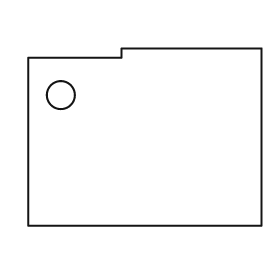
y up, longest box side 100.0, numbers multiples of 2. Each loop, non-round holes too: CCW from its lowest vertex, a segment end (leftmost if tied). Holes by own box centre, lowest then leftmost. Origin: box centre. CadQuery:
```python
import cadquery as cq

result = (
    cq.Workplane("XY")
    .moveTo(-50.0, -38.0)
    .lineTo(50.0, -38.0)
    .lineTo(50.0, 38.0)
    .lineTo(-10.0, 38.0)
    .lineTo(-10.0, 34.0)
    .lineTo(-50.0, 34.0)
    .close()
    .moveTo(-36.0, 18.0)
    .circle(6.0)
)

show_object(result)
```